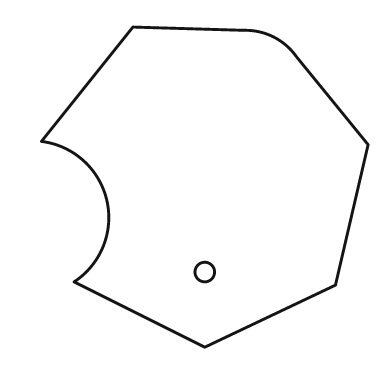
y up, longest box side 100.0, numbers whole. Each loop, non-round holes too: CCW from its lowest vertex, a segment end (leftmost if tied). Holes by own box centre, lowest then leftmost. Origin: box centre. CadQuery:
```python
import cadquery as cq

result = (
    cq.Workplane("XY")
    .moveTo(0.0, -49.0)
    .lineTo(40.0, -30.0)
    .lineTo(50.0, 13.0)
    .lineTo(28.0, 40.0)
    .threePointArc((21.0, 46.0), (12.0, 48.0))
    .lineTo(-22.0, 49.0)
    .lineTo(-50.0, 14.0)
    .threePointArc((-30.0, -4.0), (-40.0, -29.0))
    .close()
    .moveTo(0.0, -26.0)
    .circle(3.0)
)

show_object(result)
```